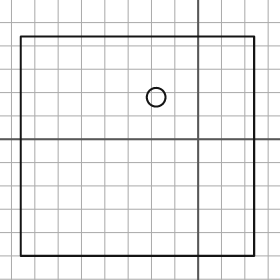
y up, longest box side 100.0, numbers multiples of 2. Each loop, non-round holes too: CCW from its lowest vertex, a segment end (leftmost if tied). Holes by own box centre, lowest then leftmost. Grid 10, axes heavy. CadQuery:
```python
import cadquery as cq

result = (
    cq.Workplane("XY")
    .moveTo(-76.0, -50.0)
    .lineTo(24.0, -50.0)
    .lineTo(24.0, 44.0)
    .lineTo(-76.0, 44.0)
    .close()
    .moveTo(-18.0, 18.0)
    .circle(4.0)
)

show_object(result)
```